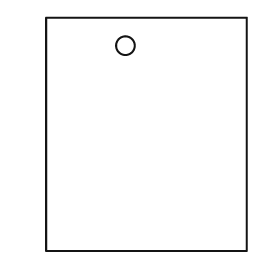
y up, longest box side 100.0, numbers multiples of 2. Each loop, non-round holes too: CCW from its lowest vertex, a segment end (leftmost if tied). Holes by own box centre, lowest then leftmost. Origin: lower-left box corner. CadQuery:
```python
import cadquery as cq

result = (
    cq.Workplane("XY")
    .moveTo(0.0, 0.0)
    .lineTo(86.0, 0.0)
    .lineTo(86.0, 100.0)
    .lineTo(0.0, 100.0)
    .close()
    .moveTo(34.0, 88.0)
    .circle(4.0)
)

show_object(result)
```